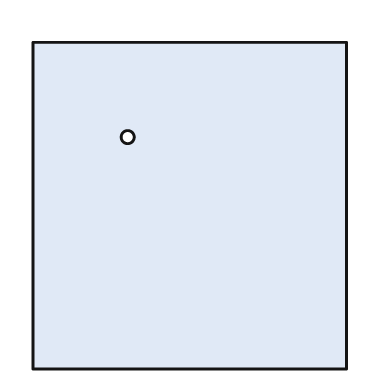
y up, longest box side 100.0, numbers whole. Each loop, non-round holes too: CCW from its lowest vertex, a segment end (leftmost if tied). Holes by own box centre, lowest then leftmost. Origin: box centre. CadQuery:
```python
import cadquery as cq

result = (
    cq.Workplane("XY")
    .moveTo(-48.0, -50.0)
    .lineTo(48.0, -50.0)
    .lineTo(48.0, 50.0)
    .lineTo(-48.0, 50.0)
    .close()
    .moveTo(-19.0, 21.0)
    .circle(2.0)
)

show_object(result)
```